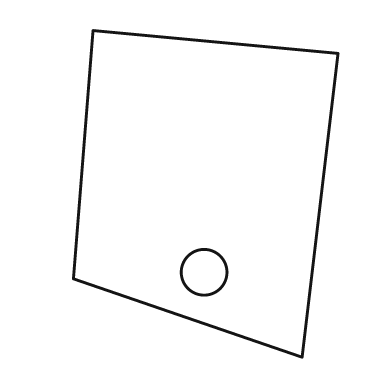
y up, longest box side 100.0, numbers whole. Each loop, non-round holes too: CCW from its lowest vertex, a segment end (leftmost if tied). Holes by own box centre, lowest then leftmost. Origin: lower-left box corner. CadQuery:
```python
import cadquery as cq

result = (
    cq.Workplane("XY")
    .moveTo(70.0, 0.0)
    .lineTo(81.0, 93.0)
    .lineTo(6.0, 100.0)
    .lineTo(0.0, 24.0)
    .close()
    .moveTo(40.0, 26.0)
    .circle(7.0)
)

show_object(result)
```